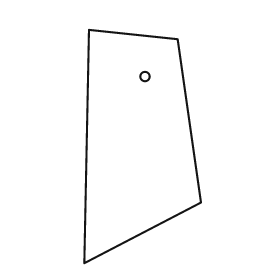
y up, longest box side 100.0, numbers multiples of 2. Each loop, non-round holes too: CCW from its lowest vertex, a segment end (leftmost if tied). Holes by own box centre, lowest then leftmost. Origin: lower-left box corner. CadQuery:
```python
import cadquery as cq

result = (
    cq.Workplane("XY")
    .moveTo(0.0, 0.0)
    .lineTo(50.0, 26.0)
    .lineTo(40.0, 96.0)
    .lineTo(2.0, 100.0)
    .close()
    .moveTo(26.0, 80.0)
    .circle(2.0)
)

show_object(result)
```